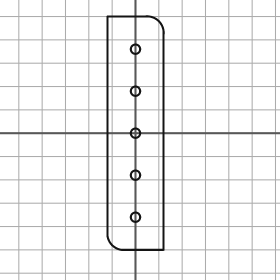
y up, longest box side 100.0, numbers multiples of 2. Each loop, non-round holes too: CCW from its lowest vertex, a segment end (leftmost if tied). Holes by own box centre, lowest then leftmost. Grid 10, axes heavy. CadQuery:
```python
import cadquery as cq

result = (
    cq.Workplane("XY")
    .moveTo(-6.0, -50.0)
    .lineTo(12.0, -50.0)
    .lineTo(12.0, 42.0)
    .threePointArc((10.0, 48.0), (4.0, 50.0))
    .lineTo(-12.0, 50.0)
    .lineTo(-12.0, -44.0)
    .threePointArc((-10.0, -48.0), (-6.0, -50.0))
    .close()
    .moveTo(0.0, -36.0)
    .circle(2.0)
    .moveTo(0.0, -18.0)
    .circle(2.0)
    .moveTo(0.0, 0.0)
    .circle(2.0)
    .moveTo(0.0, 18.0)
    .circle(2.0)
    .moveTo(0.0, 36.0)
    .circle(2.0)
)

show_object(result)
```